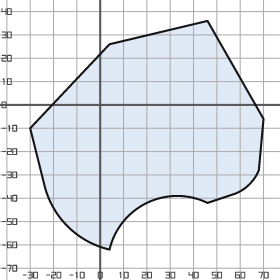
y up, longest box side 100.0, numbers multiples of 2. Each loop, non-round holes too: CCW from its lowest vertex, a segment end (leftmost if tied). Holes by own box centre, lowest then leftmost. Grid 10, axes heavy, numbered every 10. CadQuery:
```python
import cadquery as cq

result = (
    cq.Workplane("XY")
    .moveTo(4.0, -62.0)
    .threePointArc((20.0, -42.0), (46.0, -42.0))
    .lineTo(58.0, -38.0)
    .threePointArc((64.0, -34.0), (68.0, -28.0))
    .lineTo(70.0, -6.0)
    .lineTo(46.0, 36.0)
    .lineTo(4.0, 26.0)
    .lineTo(-30.0, -10.0)
    .lineTo(-24.0, -34.0)
    .threePointArc((-14.0, -52.0), (4.0, -62.0))
    .close()
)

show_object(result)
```